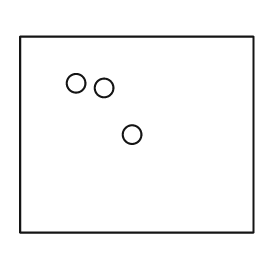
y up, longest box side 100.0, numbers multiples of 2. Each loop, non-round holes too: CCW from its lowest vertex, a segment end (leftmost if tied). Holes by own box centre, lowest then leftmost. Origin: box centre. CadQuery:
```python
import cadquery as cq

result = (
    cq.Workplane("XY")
    .moveTo(-50.0, -42.0)
    .lineTo(50.0, -42.0)
    .lineTo(50.0, 42.0)
    .lineTo(-50.0, 42.0)
    .close()
    .moveTo(-2.0, 0.0)
    .circle(4.0)
    .moveTo(-14.0, 20.0)
    .circle(4.0)
    .moveTo(-26.0, 22.0)
    .circle(4.0)
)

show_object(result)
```